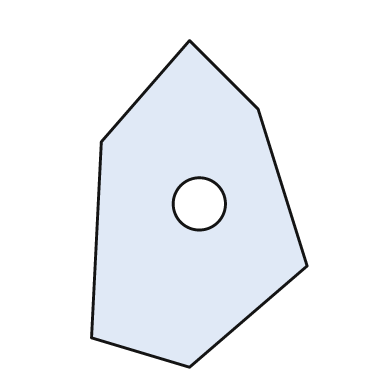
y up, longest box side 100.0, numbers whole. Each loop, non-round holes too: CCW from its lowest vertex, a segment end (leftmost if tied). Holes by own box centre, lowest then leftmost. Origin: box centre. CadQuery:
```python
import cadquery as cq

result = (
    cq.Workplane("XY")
    .moveTo(-3.0, -50.0)
    .lineTo(33.0, -19.0)
    .lineTo(18.0, 29.0)
    .lineTo(-3.0, 50.0)
    .lineTo(-30.0, 19.0)
    .lineTo(-33.0, -41.0)
    .close()
    .moveTo(0.0, 0.0)
    .circle(8.0)
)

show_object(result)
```